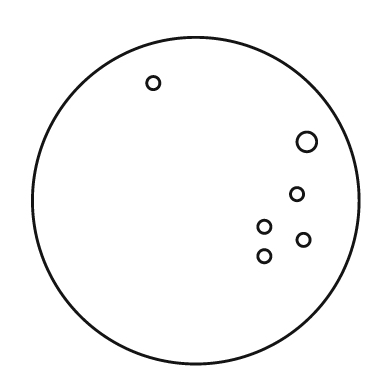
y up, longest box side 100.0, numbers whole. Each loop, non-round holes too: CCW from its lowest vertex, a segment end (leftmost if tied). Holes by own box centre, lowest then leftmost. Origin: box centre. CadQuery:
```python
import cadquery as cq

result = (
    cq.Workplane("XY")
    .moveTo(0.0, 0.0)
    .circle(50.0)
    .moveTo(21.0, -17.0)
    .circle(2.0)
    .moveTo(33.0, -12.0)
    .circle(2.0)
    .moveTo(21.0, -8.0)
    .circle(2.0)
    .moveTo(31.0, 2.0)
    .circle(2.0)
    .moveTo(34.0, 18.0)
    .circle(3.0)
    .moveTo(-13.0, 36.0)
    .circle(2.0)
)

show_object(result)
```